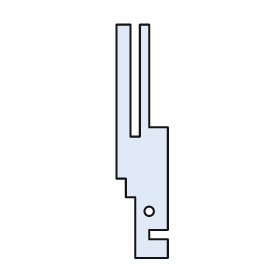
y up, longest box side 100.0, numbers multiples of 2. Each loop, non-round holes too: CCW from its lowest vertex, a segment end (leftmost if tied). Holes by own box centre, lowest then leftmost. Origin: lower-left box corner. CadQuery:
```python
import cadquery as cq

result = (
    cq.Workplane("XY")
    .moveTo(8.0, 0.0)
    .lineTo(22.0, 0.0)
    .lineTo(22.0, 8.0)
    .lineTo(14.0, 8.0)
    .lineTo(14.0, 12.0)
    .lineTo(22.0, 12.0)
    .lineTo(22.0, 56.0)
    .lineTo(14.0, 56.0)
    .lineTo(14.0, 100.0)
    .lineTo(10.0, 100.0)
    .lineTo(10.0, 52.0)
    .lineTo(6.0, 52.0)
    .lineTo(6.0, 100.0)
    .lineTo(0.0, 100.0)
    .lineTo(0.0, 34.0)
    .lineTo(4.0, 34.0)
    .lineTo(4.0, 26.0)
    .lineTo(8.0, 26.0)
    .close()
    .moveTo(14.0, 20.0)
    .circle(2.0)
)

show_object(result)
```